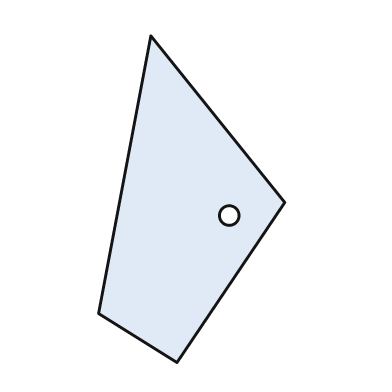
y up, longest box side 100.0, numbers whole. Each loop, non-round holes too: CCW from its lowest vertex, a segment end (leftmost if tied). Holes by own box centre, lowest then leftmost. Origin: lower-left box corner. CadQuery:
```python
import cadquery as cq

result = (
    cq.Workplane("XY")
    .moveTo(24.0, 0.0)
    .lineTo(57.0, 49.0)
    .lineTo(16.0, 100.0)
    .lineTo(0.0, 15.0)
    .close()
    .moveTo(40.0, 45.0)
    .circle(3.0)
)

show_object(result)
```